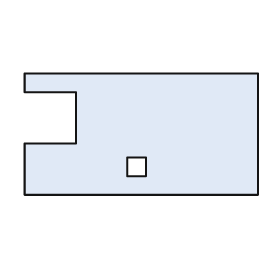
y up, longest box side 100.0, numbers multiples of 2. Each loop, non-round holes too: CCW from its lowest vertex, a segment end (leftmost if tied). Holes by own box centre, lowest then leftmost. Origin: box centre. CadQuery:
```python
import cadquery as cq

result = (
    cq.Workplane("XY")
    .moveTo(-50.0, -26.0)
    .lineTo(50.0, -26.0)
    .lineTo(50.0, 26.0)
    .lineTo(-50.0, 26.0)
    .lineTo(-50.0, 18.0)
    .lineTo(-28.0, 18.0)
    .lineTo(-28.0, -4.0)
    .lineTo(-50.0, -4.0)
    .close()
    .moveTo(-6.0, -18.0)
    .lineTo(2.0, -18.0)
    .lineTo(2.0, -10.0)
    .lineTo(-6.0, -10.0)
    .close()
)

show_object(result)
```